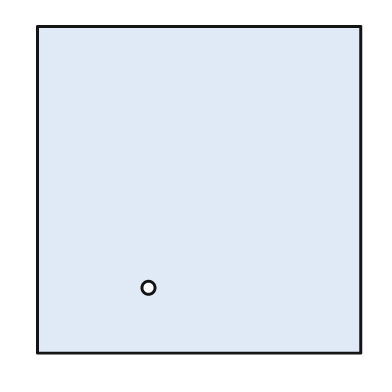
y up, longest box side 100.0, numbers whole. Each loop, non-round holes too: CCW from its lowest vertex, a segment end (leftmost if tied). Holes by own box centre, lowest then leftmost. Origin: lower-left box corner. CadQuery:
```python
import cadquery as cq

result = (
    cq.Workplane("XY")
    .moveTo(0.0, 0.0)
    .lineTo(99.0, 0.0)
    .lineTo(99.0, 100.0)
    .lineTo(0.0, 100.0)
    .close()
    .moveTo(34.0, 20.0)
    .circle(2.0)
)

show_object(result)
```